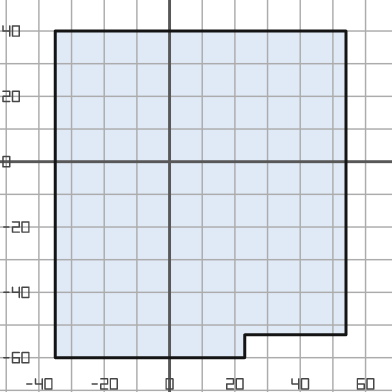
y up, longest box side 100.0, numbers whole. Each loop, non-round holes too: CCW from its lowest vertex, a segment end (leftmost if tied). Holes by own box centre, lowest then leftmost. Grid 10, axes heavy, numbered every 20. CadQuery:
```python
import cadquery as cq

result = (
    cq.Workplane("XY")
    .moveTo(-35.0, -60.0)
    .lineTo(23.0, -60.0)
    .lineTo(23.0, -53.0)
    .lineTo(54.0, -53.0)
    .lineTo(54.0, 40.0)
    .lineTo(-35.0, 40.0)
    .close()
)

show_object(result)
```